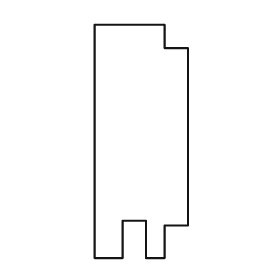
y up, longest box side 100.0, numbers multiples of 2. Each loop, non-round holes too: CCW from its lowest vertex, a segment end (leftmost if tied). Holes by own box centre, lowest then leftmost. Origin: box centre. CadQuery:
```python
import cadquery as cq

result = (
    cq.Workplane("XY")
    .moveTo(-20.0, -50.0)
    .lineTo(-8.0, -50.0)
    .lineTo(-8.0, -34.0)
    .lineTo(2.0, -34.0)
    .lineTo(2.0, -50.0)
    .lineTo(10.0, -50.0)
    .lineTo(10.0, -36.0)
    .lineTo(20.0, -36.0)
    .lineTo(20.0, 40.0)
    .lineTo(10.0, 40.0)
    .lineTo(10.0, 50.0)
    .lineTo(-20.0, 50.0)
    .close()
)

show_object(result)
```